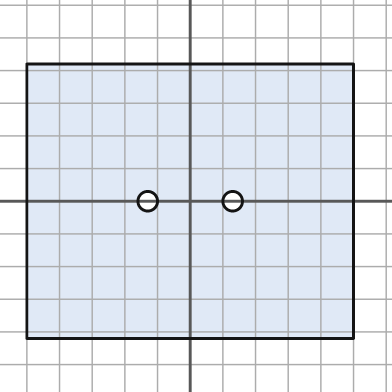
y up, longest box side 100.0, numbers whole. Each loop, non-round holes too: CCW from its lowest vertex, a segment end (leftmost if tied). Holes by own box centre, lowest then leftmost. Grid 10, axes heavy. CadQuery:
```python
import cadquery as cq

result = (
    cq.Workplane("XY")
    .moveTo(-50.0, -42.0)
    .lineTo(50.0, -42.0)
    .lineTo(50.0, 42.0)
    .lineTo(-50.0, 42.0)
    .close()
    .moveTo(-13.0, 0.0)
    .circle(3.0)
    .moveTo(13.0, 0.0)
    .circle(3.0)
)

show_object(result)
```